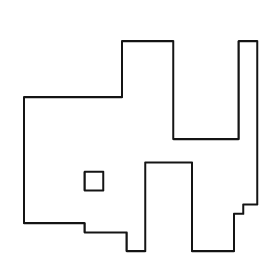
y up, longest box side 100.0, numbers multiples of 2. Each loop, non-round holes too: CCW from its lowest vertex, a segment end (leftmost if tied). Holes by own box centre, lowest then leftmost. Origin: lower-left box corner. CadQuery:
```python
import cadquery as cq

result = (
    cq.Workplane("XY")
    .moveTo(44.0, 0.0)
    .lineTo(52.0, 0.0)
    .lineTo(52.0, 38.0)
    .lineTo(72.0, 38.0)
    .lineTo(72.0, 0.0)
    .lineTo(90.0, 0.0)
    .lineTo(90.0, 16.0)
    .lineTo(94.0, 16.0)
    .lineTo(94.0, 20.0)
    .lineTo(100.0, 20.0)
    .lineTo(100.0, 90.0)
    .lineTo(92.0, 90.0)
    .lineTo(92.0, 48.0)
    .lineTo(64.0, 48.0)
    .lineTo(64.0, 90.0)
    .lineTo(42.0, 90.0)
    .lineTo(42.0, 66.0)
    .lineTo(0.0, 66.0)
    .lineTo(0.0, 12.0)
    .lineTo(26.0, 12.0)
    .lineTo(26.0, 8.0)
    .lineTo(44.0, 8.0)
    .close()
    .moveTo(26.0, 26.0)
    .lineTo(34.0, 26.0)
    .lineTo(34.0, 34.0)
    .lineTo(26.0, 34.0)
    .close()
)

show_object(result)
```